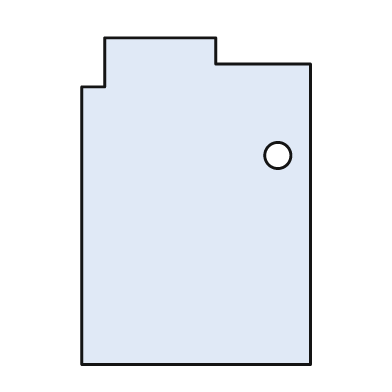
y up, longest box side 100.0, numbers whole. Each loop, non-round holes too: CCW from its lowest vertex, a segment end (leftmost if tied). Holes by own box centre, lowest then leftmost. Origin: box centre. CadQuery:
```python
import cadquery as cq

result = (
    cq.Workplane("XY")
    .moveTo(-35.0, -50.0)
    .lineTo(35.0, -50.0)
    .lineTo(35.0, 42.0)
    .lineTo(6.0, 42.0)
    .lineTo(6.0, 50.0)
    .lineTo(-28.0, 50.0)
    .lineTo(-28.0, 35.0)
    .lineTo(-35.0, 35.0)
    .close()
    .moveTo(25.0, 14.0)
    .circle(4.0)
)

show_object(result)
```